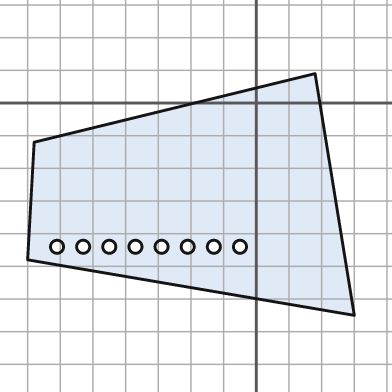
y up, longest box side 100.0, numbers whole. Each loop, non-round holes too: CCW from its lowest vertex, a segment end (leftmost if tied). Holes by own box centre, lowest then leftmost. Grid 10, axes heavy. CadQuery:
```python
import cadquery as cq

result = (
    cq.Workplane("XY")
    .moveTo(30.0, -65.0)
    .lineTo(18.0, 9.0)
    .lineTo(-68.0, -12.0)
    .lineTo(-70.0, -48.0)
    .close()
    .moveTo(-61.0, -44.0)
    .circle(2.0)
    .moveTo(-53.0, -44.0)
    .circle(2.0)
    .moveTo(-45.0, -44.0)
    .circle(2.0)
    .moveTo(-37.0, -44.0)
    .circle(2.0)
    .moveTo(-29.0, -44.0)
    .circle(2.0)
    .moveTo(-21.0, -44.0)
    .circle(2.0)
    .moveTo(-13.0, -44.0)
    .circle(2.0)
    .moveTo(-5.0, -44.0)
    .circle(2.0)
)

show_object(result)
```